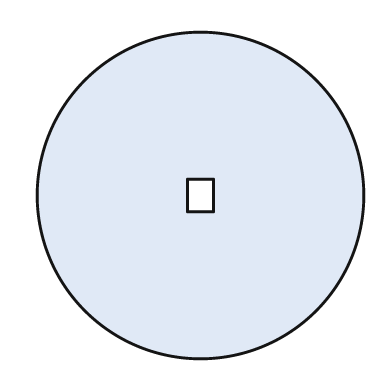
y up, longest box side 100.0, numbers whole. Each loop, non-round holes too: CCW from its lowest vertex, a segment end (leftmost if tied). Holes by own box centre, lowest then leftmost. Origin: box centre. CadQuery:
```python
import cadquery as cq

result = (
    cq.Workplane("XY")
    .moveTo(0.0, 0.0)
    .circle(50.0)
    .moveTo(-4.0, -5.0)
    .lineTo(4.0, -5.0)
    .lineTo(4.0, 5.0)
    .lineTo(-4.0, 5.0)
    .close()
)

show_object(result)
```